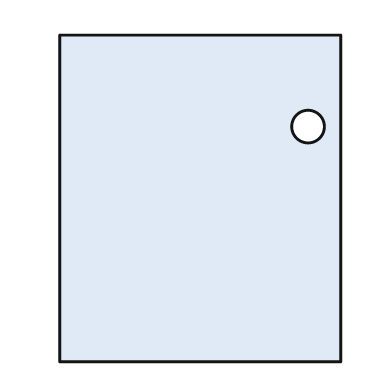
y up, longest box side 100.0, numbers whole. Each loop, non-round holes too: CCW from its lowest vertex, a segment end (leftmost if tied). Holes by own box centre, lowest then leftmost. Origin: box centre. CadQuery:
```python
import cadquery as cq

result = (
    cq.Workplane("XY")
    .moveTo(-43.0, -50.0)
    .lineTo(43.0, -50.0)
    .lineTo(43.0, 50.0)
    .lineTo(-43.0, 50.0)
    .close()
    .moveTo(33.0, 22.0)
    .circle(5.0)
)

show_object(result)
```